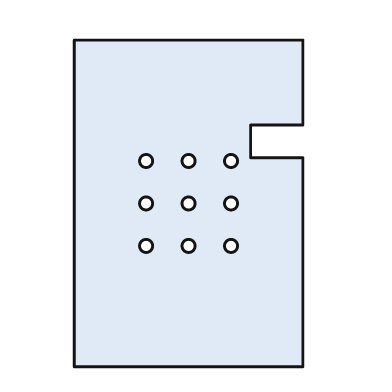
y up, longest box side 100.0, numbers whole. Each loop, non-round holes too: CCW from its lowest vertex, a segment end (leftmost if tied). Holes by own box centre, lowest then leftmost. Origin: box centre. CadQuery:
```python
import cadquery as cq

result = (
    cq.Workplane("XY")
    .moveTo(-35.0, -50.0)
    .lineTo(35.0, -50.0)
    .lineTo(35.0, 14.0)
    .lineTo(19.0, 14.0)
    .lineTo(19.0, 24.0)
    .lineTo(35.0, 24.0)
    .lineTo(35.0, 50.0)
    .lineTo(-35.0, 50.0)
    .close()
    .moveTo(-13.0, -13.0)
    .circle(2.0)
    .moveTo(0.0, -13.0)
    .circle(2.0)
    .moveTo(13.0, -13.0)
    .circle(2.0)
    .moveTo(-13.0, 0.0)
    .circle(2.0)
    .moveTo(0.0, 0.0)
    .circle(2.0)
    .moveTo(13.0, 0.0)
    .circle(2.0)
    .moveTo(-13.0, 13.0)
    .circle(2.0)
    .moveTo(0.0, 13.0)
    .circle(2.0)
    .moveTo(13.0, 13.0)
    .circle(2.0)
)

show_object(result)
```